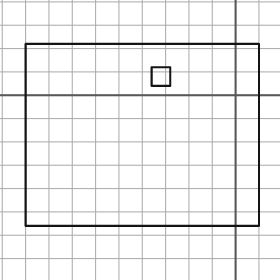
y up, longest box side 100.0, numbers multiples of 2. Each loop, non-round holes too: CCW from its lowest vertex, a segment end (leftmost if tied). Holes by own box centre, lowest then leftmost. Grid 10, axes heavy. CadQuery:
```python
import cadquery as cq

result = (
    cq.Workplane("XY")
    .moveTo(-90.0, -56.0)
    .lineTo(10.0, -56.0)
    .lineTo(10.0, 22.0)
    .lineTo(-90.0, 22.0)
    .close()
    .moveTo(-36.0, 4.0)
    .lineTo(-28.0, 4.0)
    .lineTo(-28.0, 12.0)
    .lineTo(-36.0, 12.0)
    .close()
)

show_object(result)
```